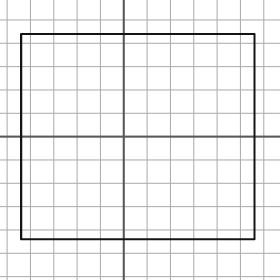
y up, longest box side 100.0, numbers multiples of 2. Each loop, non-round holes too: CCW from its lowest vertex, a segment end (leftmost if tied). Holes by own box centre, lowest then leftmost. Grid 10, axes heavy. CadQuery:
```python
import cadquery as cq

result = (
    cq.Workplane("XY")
    .moveTo(-44.0, -44.0)
    .lineTo(56.0, -44.0)
    .lineTo(56.0, 44.0)
    .lineTo(-44.0, 44.0)
    .close()
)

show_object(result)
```